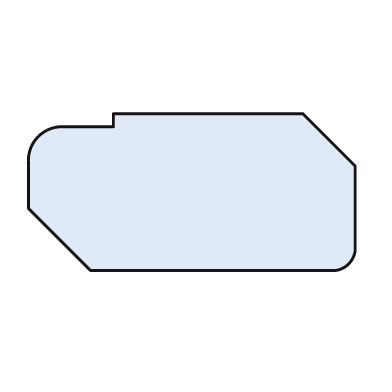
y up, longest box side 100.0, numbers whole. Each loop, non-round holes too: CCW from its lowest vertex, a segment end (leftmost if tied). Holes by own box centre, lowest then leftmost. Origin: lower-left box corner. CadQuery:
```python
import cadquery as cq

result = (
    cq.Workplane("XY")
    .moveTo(19.0, 0.0)
    .lineTo(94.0, 0.0)
    .threePointArc((98.0, 2.0), (100.0, 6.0))
    .lineTo(100.0, 32.0)
    .lineTo(84.0, 48.0)
    .lineTo(26.0, 48.0)
    .lineTo(26.0, 44.0)
    .lineTo(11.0, 44.0)
    .threePointArc((3.0, 41.0), (0.0, 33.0))
    .lineTo(0.0, 19.0)
    .close()
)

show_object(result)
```